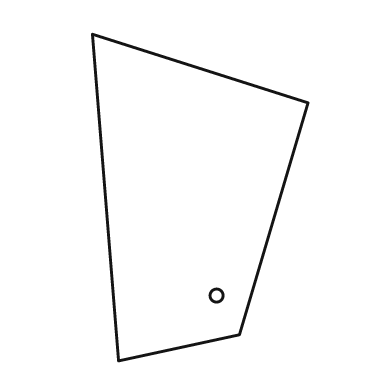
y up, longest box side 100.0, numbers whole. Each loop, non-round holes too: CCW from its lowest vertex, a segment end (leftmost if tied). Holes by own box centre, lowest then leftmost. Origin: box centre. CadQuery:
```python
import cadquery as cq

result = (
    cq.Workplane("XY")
    .moveTo(-25.0, -50.0)
    .lineTo(12.0, -42.0)
    .lineTo(33.0, 29.0)
    .lineTo(-33.0, 50.0)
    .close()
    .moveTo(5.0, -30.0)
    .circle(2.0)
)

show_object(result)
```